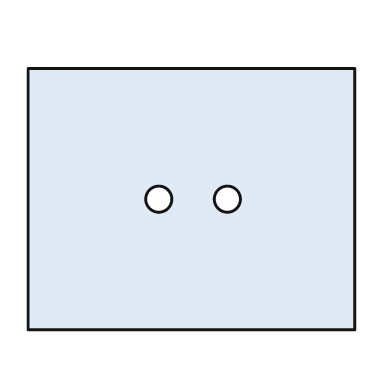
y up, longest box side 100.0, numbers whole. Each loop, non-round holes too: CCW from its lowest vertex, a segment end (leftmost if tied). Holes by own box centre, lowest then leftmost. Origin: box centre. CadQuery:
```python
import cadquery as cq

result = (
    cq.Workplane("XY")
    .moveTo(-50.0, -40.0)
    .lineTo(50.0, -40.0)
    .lineTo(50.0, 40.0)
    .lineTo(-50.0, 40.0)
    .close()
    .moveTo(-10.0, 0.0)
    .circle(4.0)
    .moveTo(11.0, 0.0)
    .circle(4.0)
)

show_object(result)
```